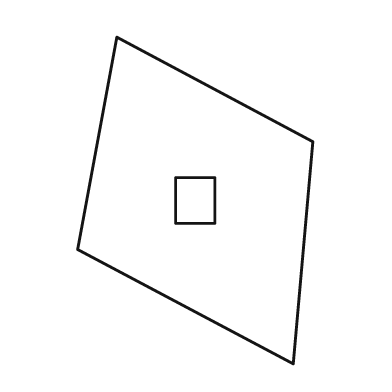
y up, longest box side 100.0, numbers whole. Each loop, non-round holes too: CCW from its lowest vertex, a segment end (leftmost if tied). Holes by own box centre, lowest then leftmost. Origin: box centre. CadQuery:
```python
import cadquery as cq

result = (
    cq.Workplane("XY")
    .moveTo(30.0, -50.0)
    .lineTo(36.0, 18.0)
    .lineTo(-24.0, 50.0)
    .lineTo(-36.0, -15.0)
    .close()
    .moveTo(-6.0, -7.0)
    .lineTo(6.0, -7.0)
    .lineTo(6.0, 7.0)
    .lineTo(-6.0, 7.0)
    .close()
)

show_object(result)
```